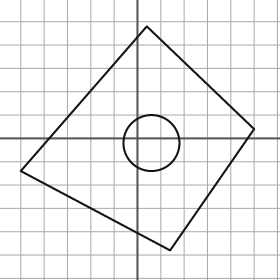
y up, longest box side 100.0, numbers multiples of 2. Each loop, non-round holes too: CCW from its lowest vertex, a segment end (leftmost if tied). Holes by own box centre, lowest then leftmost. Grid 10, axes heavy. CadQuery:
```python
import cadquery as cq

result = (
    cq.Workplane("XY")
    .moveTo(14.0, -48.0)
    .lineTo(50.0, 4.0)
    .lineTo(4.0, 48.0)
    .lineTo(-50.0, -14.0)
    .close()
    .moveTo(6.0, -2.0)
    .circle(12.0)
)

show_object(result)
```